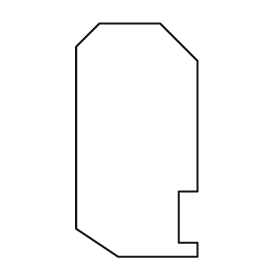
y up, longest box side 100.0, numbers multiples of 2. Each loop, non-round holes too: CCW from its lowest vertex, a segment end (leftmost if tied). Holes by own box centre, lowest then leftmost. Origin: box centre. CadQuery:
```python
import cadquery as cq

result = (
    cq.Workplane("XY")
    .moveTo(-8.0, -50.0)
    .lineTo(26.0, -50.0)
    .lineTo(26.0, -44.0)
    .lineTo(18.0, -44.0)
    .lineTo(18.0, -22.0)
    .lineTo(26.0, -22.0)
    .lineTo(26.0, 34.0)
    .lineTo(10.0, 50.0)
    .lineTo(-16.0, 50.0)
    .lineTo(-26.0, 40.0)
    .lineTo(-26.0, -38.0)
    .close()
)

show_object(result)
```